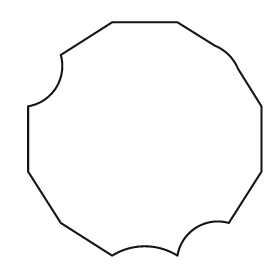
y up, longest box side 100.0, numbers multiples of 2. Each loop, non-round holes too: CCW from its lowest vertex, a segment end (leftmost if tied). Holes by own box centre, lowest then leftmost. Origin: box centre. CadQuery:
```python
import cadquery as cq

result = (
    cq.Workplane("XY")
    .moveTo(-14.0, -50.0)
    .threePointArc((0.0, -46.0), (14.0, -50.0))
    .threePointArc((22.0, -38.0), (36.0, -36.0))
    .lineTo(50.0, -14.0)
    .lineTo(50.0, 14.0)
    .lineTo(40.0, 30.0)
    .threePointArc((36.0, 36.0), (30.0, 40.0))
    .lineTo(14.0, 50.0)
    .lineTo(-14.0, 50.0)
    .lineTo(-36.0, 36.0)
    .threePointArc((-38.0, 22.0), (-50.0, 14.0))
    .lineTo(-50.0, -14.0)
    .lineTo(-36.0, -36.0)
    .close()
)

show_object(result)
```